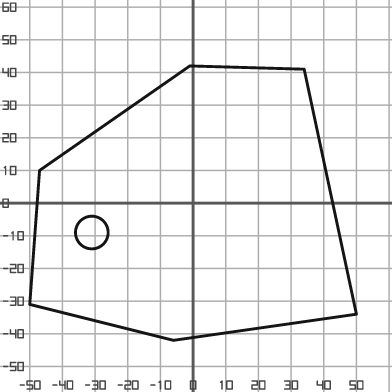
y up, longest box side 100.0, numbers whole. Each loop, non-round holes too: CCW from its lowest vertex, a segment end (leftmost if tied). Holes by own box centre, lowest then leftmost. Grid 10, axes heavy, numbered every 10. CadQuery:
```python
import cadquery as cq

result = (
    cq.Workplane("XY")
    .moveTo(-6.0, -42.0)
    .lineTo(50.0, -34.0)
    .lineTo(34.0, 41.0)
    .lineTo(-1.0, 42.0)
    .lineTo(-47.0, 10.0)
    .lineTo(-50.0, -31.0)
    .close()
    .moveTo(-31.0, -9.0)
    .circle(5.0)
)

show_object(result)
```